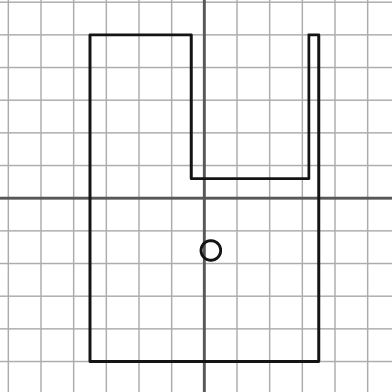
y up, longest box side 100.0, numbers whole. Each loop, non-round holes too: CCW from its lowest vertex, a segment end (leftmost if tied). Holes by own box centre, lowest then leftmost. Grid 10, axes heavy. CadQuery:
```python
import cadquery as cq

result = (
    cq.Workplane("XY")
    .moveTo(-35.0, -50.0)
    .lineTo(35.0, -50.0)
    .lineTo(35.0, 50.0)
    .lineTo(32.0, 50.0)
    .lineTo(32.0, 6.0)
    .lineTo(-4.0, 6.0)
    .lineTo(-4.0, 50.0)
    .lineTo(-35.0, 50.0)
    .close()
    .moveTo(2.0, -16.0)
    .circle(3.0)
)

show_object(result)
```